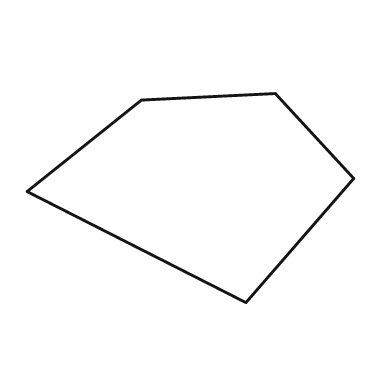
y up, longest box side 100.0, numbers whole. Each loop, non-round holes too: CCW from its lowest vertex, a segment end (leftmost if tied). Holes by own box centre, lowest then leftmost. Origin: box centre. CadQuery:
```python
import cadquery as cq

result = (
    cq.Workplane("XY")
    .moveTo(17.0, -32.0)
    .lineTo(50.0, 6.0)
    .lineTo(26.0, 32.0)
    .lineTo(-15.0, 30.0)
    .lineTo(-50.0, 2.0)
    .close()
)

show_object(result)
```